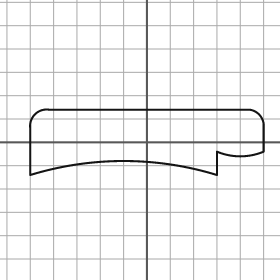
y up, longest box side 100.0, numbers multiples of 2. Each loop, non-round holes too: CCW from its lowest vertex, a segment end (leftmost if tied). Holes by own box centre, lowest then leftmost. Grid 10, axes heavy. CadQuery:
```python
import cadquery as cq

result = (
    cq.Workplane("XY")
    .moveTo(-50.0, -14.0)
    .threePointArc((-10.0, -8.0), (30.0, -14.0))
    .lineTo(30.0, -4.0)
    .threePointArc((40.0, -6.0), (50.0, -4.0))
    .lineTo(50.0, 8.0)
    .threePointArc((48.0, 12.0), (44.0, 14.0))
    .lineTo(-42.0, 14.0)
    .threePointArc((-48.0, 12.0), (-50.0, 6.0))
    .close()
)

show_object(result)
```